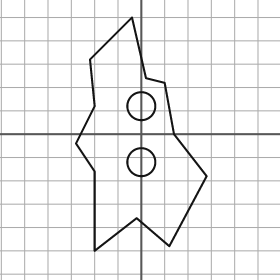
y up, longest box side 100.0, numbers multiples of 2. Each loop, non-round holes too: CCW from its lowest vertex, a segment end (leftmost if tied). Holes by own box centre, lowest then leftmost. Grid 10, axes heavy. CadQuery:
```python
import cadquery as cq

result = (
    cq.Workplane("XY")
    .moveTo(-20.0, -50.0)
    .lineTo(-2.0, -36.0)
    .lineTo(12.0, -48.0)
    .lineTo(28.0, -18.0)
    .lineTo(14.0, 0.0)
    .lineTo(10.0, 22.0)
    .lineTo(2.0, 24.0)
    .lineTo(-4.0, 50.0)
    .lineTo(-22.0, 32.0)
    .lineTo(-20.0, 12.0)
    .lineTo(-28.0, -4.0)
    .lineTo(-20.0, -16.0)
    .close()
    .moveTo(0.0, -12.0)
    .circle(6.0)
    .moveTo(0.0, 12.0)
    .circle(6.0)
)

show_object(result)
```